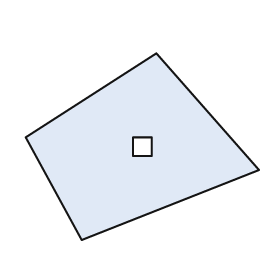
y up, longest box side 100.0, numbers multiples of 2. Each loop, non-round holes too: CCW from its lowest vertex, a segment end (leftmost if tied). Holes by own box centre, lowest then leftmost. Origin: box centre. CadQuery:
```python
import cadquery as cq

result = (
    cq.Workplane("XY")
    .moveTo(-26.0, -40.0)
    .lineTo(50.0, -10.0)
    .lineTo(6.0, 40.0)
    .lineTo(-50.0, 4.0)
    .close()
    .moveTo(-4.0, -4.0)
    .lineTo(4.0, -4.0)
    .lineTo(4.0, 4.0)
    .lineTo(-4.0, 4.0)
    .close()
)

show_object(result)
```